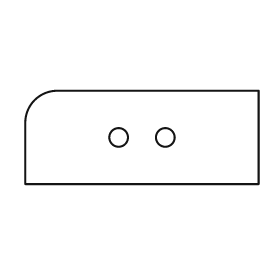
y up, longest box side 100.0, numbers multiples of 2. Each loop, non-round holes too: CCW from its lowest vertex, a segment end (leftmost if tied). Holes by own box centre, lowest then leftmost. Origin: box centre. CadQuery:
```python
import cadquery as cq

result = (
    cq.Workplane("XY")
    .moveTo(-50.0, -20.0)
    .lineTo(50.0, -20.0)
    .lineTo(50.0, 20.0)
    .lineTo(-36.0, 20.0)
    .threePointArc((-46.0, 16.0), (-50.0, 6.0))
    .close()
    .moveTo(-10.0, 0.0)
    .circle(4.0)
    .moveTo(10.0, 0.0)
    .circle(4.0)
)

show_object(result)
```